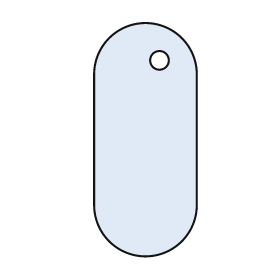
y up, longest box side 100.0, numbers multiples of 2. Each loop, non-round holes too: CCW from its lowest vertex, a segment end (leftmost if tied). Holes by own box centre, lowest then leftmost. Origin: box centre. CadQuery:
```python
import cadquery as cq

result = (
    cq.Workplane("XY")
    .moveTo(-22.0, -28.0)
    .threePointArc((0.0, -50.0), (22.0, -28.0))
    .lineTo(22.0, 28.0)
    .threePointArc((0.0, 50.0), (-22.0, 28.0))
    .close()
    .moveTo(6.0, 34.0)
    .circle(4.0)
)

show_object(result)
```